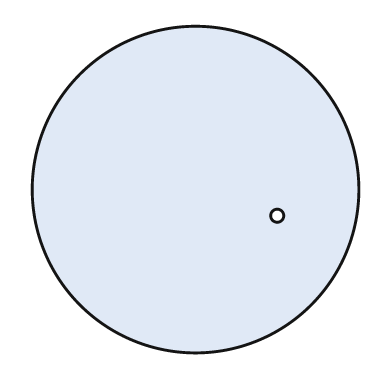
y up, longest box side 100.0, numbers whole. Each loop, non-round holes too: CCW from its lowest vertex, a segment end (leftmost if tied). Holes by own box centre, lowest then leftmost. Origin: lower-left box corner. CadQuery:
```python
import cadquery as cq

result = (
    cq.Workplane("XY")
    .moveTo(50.0, 50.0)
    .circle(50.0)
    .moveTo(75.0, 42.0)
    .circle(2.0)
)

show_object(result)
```